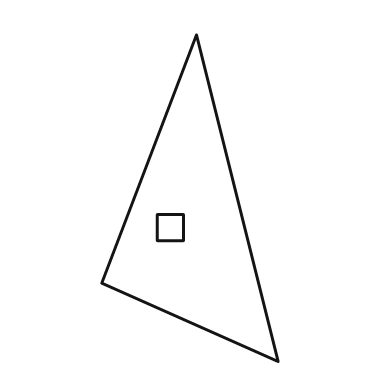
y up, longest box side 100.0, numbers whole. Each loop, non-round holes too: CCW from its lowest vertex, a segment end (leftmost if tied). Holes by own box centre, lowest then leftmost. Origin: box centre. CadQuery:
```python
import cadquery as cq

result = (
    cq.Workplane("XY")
    .moveTo(27.0, -50.0)
    .lineTo(2.0, 50.0)
    .lineTo(-27.0, -26.0)
    .close()
    .moveTo(-10.0, -13.0)
    .lineTo(-2.0, -13.0)
    .lineTo(-2.0, -5.0)
    .lineTo(-10.0, -5.0)
    .close()
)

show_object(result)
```